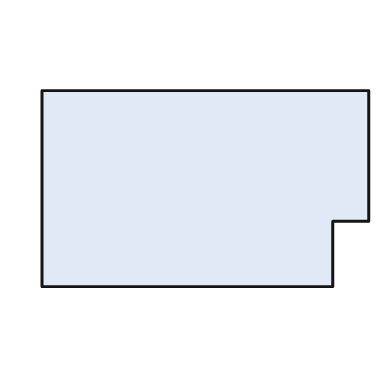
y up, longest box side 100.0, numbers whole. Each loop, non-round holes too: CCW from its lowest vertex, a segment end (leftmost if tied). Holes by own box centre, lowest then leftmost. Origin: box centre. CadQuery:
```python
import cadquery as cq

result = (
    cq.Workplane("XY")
    .moveTo(-50.0, -30.0)
    .lineTo(39.0, -30.0)
    .lineTo(39.0, -10.0)
    .lineTo(50.0, -10.0)
    .lineTo(50.0, 30.0)
    .lineTo(-50.0, 30.0)
    .close()
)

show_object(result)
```